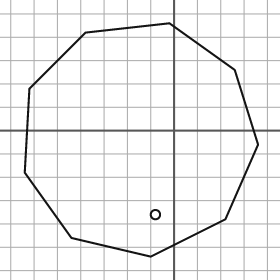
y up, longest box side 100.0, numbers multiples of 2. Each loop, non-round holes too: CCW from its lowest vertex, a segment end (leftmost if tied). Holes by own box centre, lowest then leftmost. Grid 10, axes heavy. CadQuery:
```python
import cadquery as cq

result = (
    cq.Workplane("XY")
    .moveTo(-10.0, -54.0)
    .lineTo(22.0, -38.0)
    .lineTo(36.0, -6.0)
    .lineTo(26.0, 26.0)
    .lineTo(-2.0, 46.0)
    .lineTo(-38.0, 42.0)
    .lineTo(-62.0, 18.0)
    .lineTo(-64.0, -18.0)
    .lineTo(-44.0, -46.0)
    .close()
    .moveTo(-8.0, -36.0)
    .circle(2.0)
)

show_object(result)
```